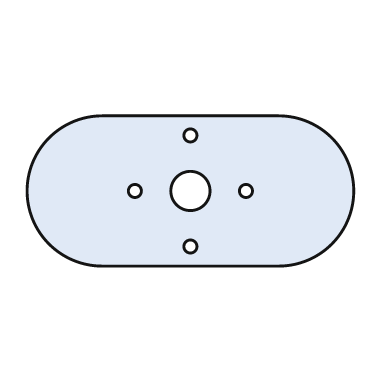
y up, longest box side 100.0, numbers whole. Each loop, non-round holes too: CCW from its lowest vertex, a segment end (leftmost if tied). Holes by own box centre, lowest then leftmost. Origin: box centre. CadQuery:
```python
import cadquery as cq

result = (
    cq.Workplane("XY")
    .moveTo(-27.0, -23.0)
    .lineTo(27.0, -23.0)
    .threePointArc((50.0, 0.0), (27.0, 23.0))
    .lineTo(-27.0, 23.0)
    .threePointArc((-50.0, 0.0), (-27.0, -23.0))
    .close()
    .moveTo(0.0, -17.0)
    .circle(2.0)
    .moveTo(-17.0, 0.0)
    .circle(2.0)
    .moveTo(0.0, 0.0)
    .circle(6.0)
    .moveTo(17.0, 0.0)
    .circle(2.0)
    .moveTo(0.0, 17.0)
    .circle(2.0)
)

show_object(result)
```